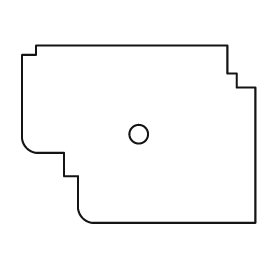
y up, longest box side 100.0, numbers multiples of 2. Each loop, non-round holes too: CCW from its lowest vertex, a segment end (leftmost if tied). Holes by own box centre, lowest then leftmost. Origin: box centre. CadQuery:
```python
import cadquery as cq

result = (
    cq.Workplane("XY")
    .moveTo(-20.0, -38.0)
    .lineTo(50.0, -38.0)
    .lineTo(50.0, 20.0)
    .lineTo(42.0, 20.0)
    .lineTo(42.0, 26.0)
    .lineTo(38.0, 26.0)
    .lineTo(38.0, 38.0)
    .lineTo(-44.0, 38.0)
    .lineTo(-44.0, 34.0)
    .lineTo(-50.0, 34.0)
    .lineTo(-50.0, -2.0)
    .threePointArc((-48.0, -6.0), (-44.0, -8.0))
    .lineTo(-32.0, -8.0)
    .lineTo(-32.0, -18.0)
    .lineTo(-26.0, -18.0)
    .lineTo(-26.0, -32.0)
    .threePointArc((-24.0, -36.0), (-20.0, -38.0))
    .close()
    .moveTo(0.0, 0.0)
    .circle(4.0)
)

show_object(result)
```